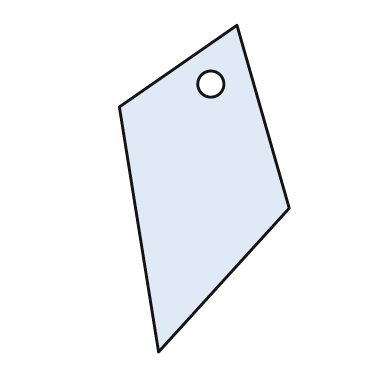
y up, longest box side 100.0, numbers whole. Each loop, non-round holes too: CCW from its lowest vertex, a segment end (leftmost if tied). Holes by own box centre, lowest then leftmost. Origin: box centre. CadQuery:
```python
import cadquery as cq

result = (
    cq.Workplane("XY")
    .moveTo(-14.0, -50.0)
    .lineTo(26.0, -6.0)
    .lineTo(10.0, 50.0)
    .lineTo(-26.0, 25.0)
    .close()
    .moveTo(2.0, 32.0)
    .circle(4.0)
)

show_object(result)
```